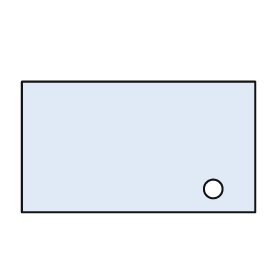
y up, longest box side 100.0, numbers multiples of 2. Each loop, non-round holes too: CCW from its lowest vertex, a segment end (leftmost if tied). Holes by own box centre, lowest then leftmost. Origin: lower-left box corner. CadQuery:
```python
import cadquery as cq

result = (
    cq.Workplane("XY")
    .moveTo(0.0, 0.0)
    .lineTo(100.0, 0.0)
    .lineTo(100.0, 56.0)
    .lineTo(0.0, 56.0)
    .close()
    .moveTo(82.0, 10.0)
    .circle(4.0)
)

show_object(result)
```